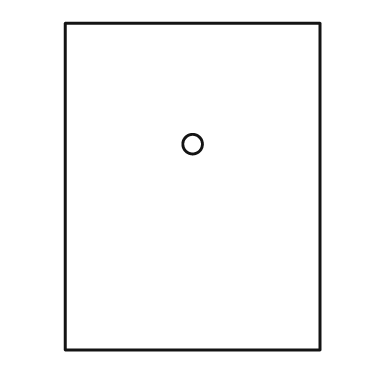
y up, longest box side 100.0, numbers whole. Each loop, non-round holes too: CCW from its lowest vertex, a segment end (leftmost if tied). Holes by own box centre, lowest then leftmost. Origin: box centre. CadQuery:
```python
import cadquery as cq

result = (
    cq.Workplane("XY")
    .moveTo(-39.0, -50.0)
    .lineTo(39.0, -50.0)
    .lineTo(39.0, 50.0)
    .lineTo(-39.0, 50.0)
    .close()
    .moveTo(0.0, 13.0)
    .circle(3.0)
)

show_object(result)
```